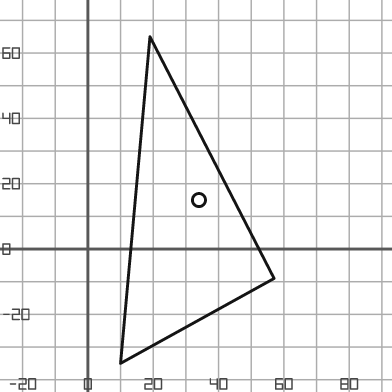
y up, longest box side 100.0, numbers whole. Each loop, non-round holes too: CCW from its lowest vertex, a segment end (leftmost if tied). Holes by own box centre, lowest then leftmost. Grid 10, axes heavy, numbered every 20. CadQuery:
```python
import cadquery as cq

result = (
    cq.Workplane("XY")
    .moveTo(10.0, -35.0)
    .lineTo(57.0, -9.0)
    .lineTo(19.0, 65.0)
    .close()
    .moveTo(34.0, 15.0)
    .circle(2.0)
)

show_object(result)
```